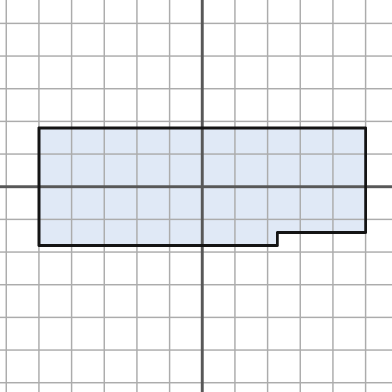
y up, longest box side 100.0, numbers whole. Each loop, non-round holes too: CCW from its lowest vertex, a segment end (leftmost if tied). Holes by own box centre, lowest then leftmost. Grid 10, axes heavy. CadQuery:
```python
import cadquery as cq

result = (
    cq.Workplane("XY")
    .moveTo(-50.0, -18.0)
    .lineTo(23.0, -18.0)
    .lineTo(23.0, -14.0)
    .lineTo(50.0, -14.0)
    .lineTo(50.0, 18.0)
    .lineTo(-50.0, 18.0)
    .close()
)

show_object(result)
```